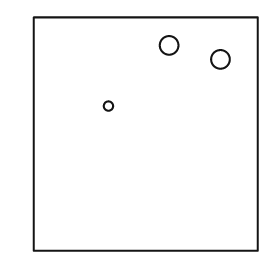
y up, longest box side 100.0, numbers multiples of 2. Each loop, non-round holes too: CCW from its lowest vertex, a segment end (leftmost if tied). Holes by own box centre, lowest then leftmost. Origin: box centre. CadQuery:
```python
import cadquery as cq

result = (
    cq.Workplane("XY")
    .moveTo(-48.0, -50.0)
    .lineTo(48.0, -50.0)
    .lineTo(48.0, 50.0)
    .lineTo(-48.0, 50.0)
    .close()
    .moveTo(-16.0, 12.0)
    .circle(2.0)
    .moveTo(32.0, 32.0)
    .circle(4.0)
    .moveTo(10.0, 38.0)
    .circle(4.0)
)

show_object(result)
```